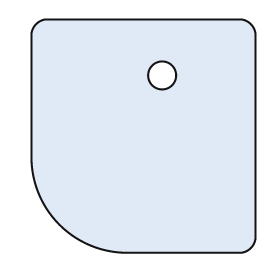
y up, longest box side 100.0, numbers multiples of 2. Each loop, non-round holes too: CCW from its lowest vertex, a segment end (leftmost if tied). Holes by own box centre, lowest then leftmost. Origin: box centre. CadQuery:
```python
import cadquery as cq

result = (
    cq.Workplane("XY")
    .moveTo(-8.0, -50.0)
    .lineTo(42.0, -50.0)
    .threePointArc((46.0, -48.0), (48.0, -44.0))
    .lineTo(48.0, 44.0)
    .threePointArc((46.0, 48.0), (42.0, 50.0))
    .lineTo(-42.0, 50.0)
    .threePointArc((-46.0, 48.0), (-48.0, 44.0))
    .lineTo(-48.0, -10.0)
    .threePointArc((-36.0, -38.0), (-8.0, -50.0))
    .close()
    .moveTo(8.0, 26.0)
    .circle(6.0)
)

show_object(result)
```